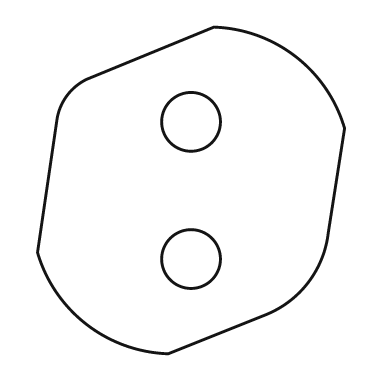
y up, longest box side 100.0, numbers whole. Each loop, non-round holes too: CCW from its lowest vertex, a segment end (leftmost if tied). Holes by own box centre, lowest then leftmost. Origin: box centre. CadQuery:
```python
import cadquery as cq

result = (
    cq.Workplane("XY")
    .moveTo(-7.0, -50.0)
    .lineTo(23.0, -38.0)
    .threePointArc((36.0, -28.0), (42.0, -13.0))
    .lineTo(47.0, 19.0)
    .threePointArc((32.0, 41.0), (7.0, 50.0))
    .lineTo(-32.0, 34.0)
    .threePointArc((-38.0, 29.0), (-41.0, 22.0))
    .lineTo(-47.0, -19.0)
    .threePointArc((-32.0, -41.0), (-7.0, -50.0))
    .close()
    .moveTo(0.0, -21.0)
    .circle(9.0)
    .moveTo(0.0, 21.0)
    .circle(9.0)
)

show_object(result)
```